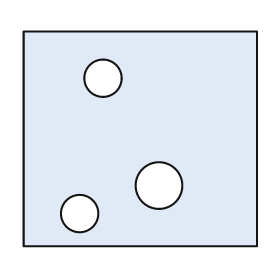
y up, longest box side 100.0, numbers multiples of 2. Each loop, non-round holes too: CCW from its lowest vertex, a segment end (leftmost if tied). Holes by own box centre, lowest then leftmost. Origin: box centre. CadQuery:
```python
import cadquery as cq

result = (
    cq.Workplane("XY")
    .moveTo(-50.0, -46.0)
    .lineTo(50.0, -46.0)
    .lineTo(50.0, 46.0)
    .lineTo(-50.0, 46.0)
    .close()
    .moveTo(-26.0, -32.0)
    .circle(8.0)
    .moveTo(8.0, -20.0)
    .circle(10.0)
    .moveTo(-16.0, 26.0)
    .circle(8.0)
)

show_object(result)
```